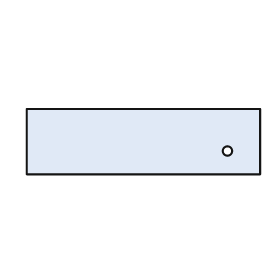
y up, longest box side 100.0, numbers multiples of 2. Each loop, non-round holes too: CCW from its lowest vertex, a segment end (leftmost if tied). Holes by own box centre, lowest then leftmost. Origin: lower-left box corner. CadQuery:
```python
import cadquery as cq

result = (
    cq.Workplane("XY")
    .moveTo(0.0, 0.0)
    .lineTo(100.0, 0.0)
    .lineTo(100.0, 28.0)
    .lineTo(0.0, 28.0)
    .close()
    .moveTo(86.0, 10.0)
    .circle(2.0)
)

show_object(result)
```